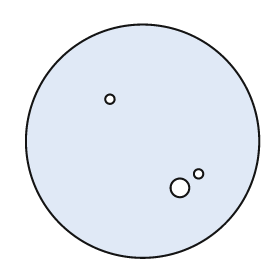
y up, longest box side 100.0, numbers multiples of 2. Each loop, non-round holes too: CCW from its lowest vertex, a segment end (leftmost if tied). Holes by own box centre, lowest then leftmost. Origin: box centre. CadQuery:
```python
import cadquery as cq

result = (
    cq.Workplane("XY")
    .moveTo(0.0, 0.0)
    .circle(50.0)
    .moveTo(16.0, -20.0)
    .circle(4.0)
    .moveTo(24.0, -14.0)
    .circle(2.0)
    .moveTo(-14.0, 18.0)
    .circle(2.0)
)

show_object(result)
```